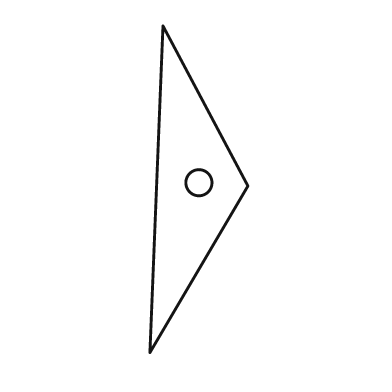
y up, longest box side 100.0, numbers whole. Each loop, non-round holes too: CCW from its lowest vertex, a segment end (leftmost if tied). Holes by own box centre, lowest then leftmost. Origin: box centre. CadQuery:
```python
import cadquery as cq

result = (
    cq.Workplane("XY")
    .moveTo(-15.0, -50.0)
    .lineTo(15.0, 1.0)
    .lineTo(-11.0, 50.0)
    .close()
    .moveTo(0.0, 2.0)
    .circle(4.0)
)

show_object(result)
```